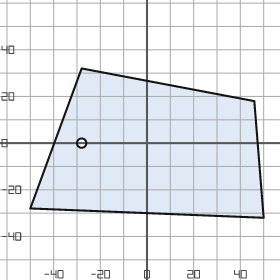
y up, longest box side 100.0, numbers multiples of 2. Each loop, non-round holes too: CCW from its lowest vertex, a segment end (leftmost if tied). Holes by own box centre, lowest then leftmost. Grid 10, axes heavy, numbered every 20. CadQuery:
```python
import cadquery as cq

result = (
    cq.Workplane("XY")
    .moveTo(50.0, -32.0)
    .lineTo(46.0, 18.0)
    .lineTo(-28.0, 32.0)
    .lineTo(-50.0, -28.0)
    .close()
    .moveTo(-28.0, 0.0)
    .circle(2.0)
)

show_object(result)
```